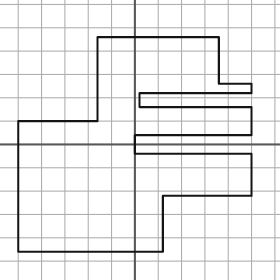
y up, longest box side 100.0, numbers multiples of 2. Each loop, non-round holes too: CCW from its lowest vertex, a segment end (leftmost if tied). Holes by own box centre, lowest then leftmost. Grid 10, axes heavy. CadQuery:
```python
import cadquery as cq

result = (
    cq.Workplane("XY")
    .moveTo(-50.0, -46.0)
    .lineTo(12.0, -46.0)
    .lineTo(12.0, -22.0)
    .lineTo(50.0, -22.0)
    .lineTo(50.0, -4.0)
    .lineTo(0.0, -4.0)
    .lineTo(0.0, 4.0)
    .lineTo(50.0, 4.0)
    .lineTo(50.0, 16.0)
    .lineTo(2.0, 16.0)
    .lineTo(2.0, 22.0)
    .lineTo(50.0, 22.0)
    .lineTo(50.0, 26.0)
    .lineTo(36.0, 26.0)
    .lineTo(36.0, 46.0)
    .lineTo(-16.0, 46.0)
    .lineTo(-16.0, 10.0)
    .lineTo(-50.0, 10.0)
    .close()
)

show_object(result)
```